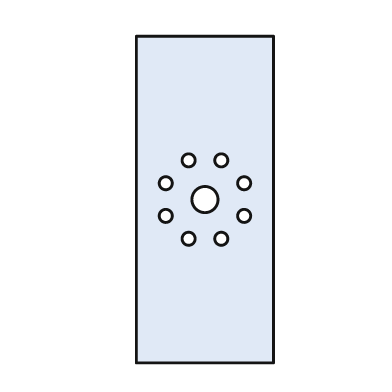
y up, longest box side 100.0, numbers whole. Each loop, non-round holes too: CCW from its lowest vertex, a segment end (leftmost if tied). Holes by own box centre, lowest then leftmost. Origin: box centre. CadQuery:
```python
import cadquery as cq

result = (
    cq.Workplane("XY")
    .moveTo(-21.0, -50.0)
    .lineTo(21.0, -50.0)
    .lineTo(21.0, 50.0)
    .lineTo(-21.0, 50.0)
    .close()
    .moveTo(-5.0, -12.0)
    .circle(2.0)
    .moveTo(5.0, -12.0)
    .circle(2.0)
    .moveTo(-12.0, -5.0)
    .circle(2.0)
    .moveTo(12.0, -5.0)
    .circle(2.0)
    .moveTo(0.0, 0.0)
    .circle(4.0)
    .moveTo(-12.0, 5.0)
    .circle(2.0)
    .moveTo(12.0, 5.0)
    .circle(2.0)
    .moveTo(-5.0, 12.0)
    .circle(2.0)
    .moveTo(5.0, 12.0)
    .circle(2.0)
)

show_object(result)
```